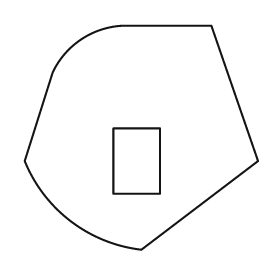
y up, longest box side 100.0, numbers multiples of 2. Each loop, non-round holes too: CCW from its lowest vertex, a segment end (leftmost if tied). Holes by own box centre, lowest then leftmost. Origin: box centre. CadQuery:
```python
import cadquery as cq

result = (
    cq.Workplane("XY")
    .moveTo(0.0, -48.0)
    .lineTo(50.0, -10.0)
    .lineTo(30.0, 48.0)
    .lineTo(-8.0, 48.0)
    .threePointArc((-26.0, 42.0), (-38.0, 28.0))
    .lineTo(-50.0, -10.0)
    .threePointArc((-30.0, -36.0), (0.0, -48.0))
    .close()
    .moveTo(-12.0, -24.0)
    .lineTo(8.0, -24.0)
    .lineTo(8.0, 4.0)
    .lineTo(-12.0, 4.0)
    .close()
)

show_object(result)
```